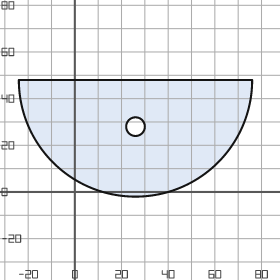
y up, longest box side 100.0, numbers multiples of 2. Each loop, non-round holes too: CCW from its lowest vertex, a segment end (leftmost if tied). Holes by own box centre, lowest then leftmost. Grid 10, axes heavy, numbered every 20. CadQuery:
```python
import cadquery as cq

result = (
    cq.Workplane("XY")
    .moveTo(-24.0, 48.0)
    .threePointArc((26.0, -2.0), (76.0, 48.0))
    .close()
    .moveTo(26.0, 28.0)
    .circle(4.0)
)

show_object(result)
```